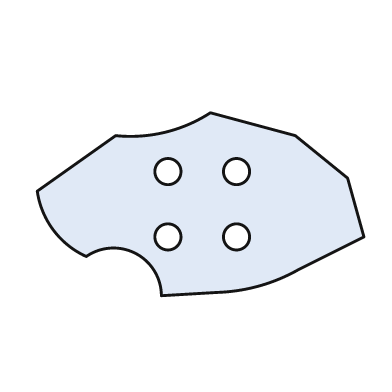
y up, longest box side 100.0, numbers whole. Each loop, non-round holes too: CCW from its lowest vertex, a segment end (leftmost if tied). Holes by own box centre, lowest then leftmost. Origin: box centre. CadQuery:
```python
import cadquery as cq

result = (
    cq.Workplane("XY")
    .moveTo(-12.0, -28.0)
    .lineTo(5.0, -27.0)
    .threePointArc((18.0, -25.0), (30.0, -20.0))
    .lineTo(50.0, -10.0)
    .lineTo(45.0, 8.0)
    .lineTo(29.0, 21.0)
    .lineTo(3.0, 28.0)
    .threePointArc((-11.0, 22.0), (-26.0, 21.0))
    .lineTo(-50.0, 4.0)
    .threePointArc((-45.0, -8.0), (-35.0, -16.0))
    .threePointArc((-20.0, -15.0), (-12.0, -28.0))
    .close()
    .moveTo(-10.0, -10.0)
    .circle(4.0)
    .moveTo(11.0, -10.0)
    .circle(4.0)
    .moveTo(-10.0, 10.0)
    .circle(4.0)
    .moveTo(11.0, 10.0)
    .circle(4.0)
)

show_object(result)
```